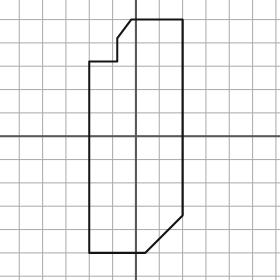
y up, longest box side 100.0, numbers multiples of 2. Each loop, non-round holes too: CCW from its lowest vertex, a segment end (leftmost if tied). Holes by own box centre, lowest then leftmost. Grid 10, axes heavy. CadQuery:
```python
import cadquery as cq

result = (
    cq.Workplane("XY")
    .moveTo(-20.0, -50.0)
    .lineTo(4.0, -50.0)
    .lineTo(20.0, -34.0)
    .lineTo(20.0, 50.0)
    .lineTo(-2.0, 50.0)
    .lineTo(-8.0, 42.0)
    .lineTo(-8.0, 32.0)
    .lineTo(-20.0, 32.0)
    .close()
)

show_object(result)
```